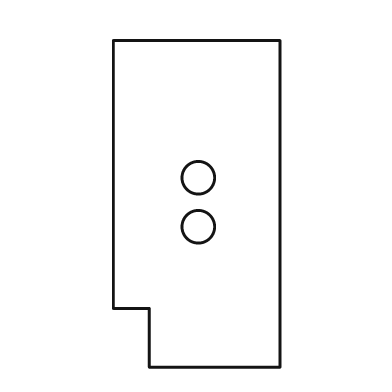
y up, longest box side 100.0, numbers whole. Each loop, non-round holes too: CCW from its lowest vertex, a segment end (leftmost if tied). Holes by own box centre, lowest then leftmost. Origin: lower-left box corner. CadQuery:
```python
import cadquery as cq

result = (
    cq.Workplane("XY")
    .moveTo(11.0, 0.0)
    .lineTo(51.0, 0.0)
    .lineTo(51.0, 100.0)
    .lineTo(0.0, 100.0)
    .lineTo(0.0, 18.0)
    .lineTo(11.0, 18.0)
    .close()
    .moveTo(26.0, 43.0)
    .circle(5.0)
    .moveTo(26.0, 58.0)
    .circle(5.0)
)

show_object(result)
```